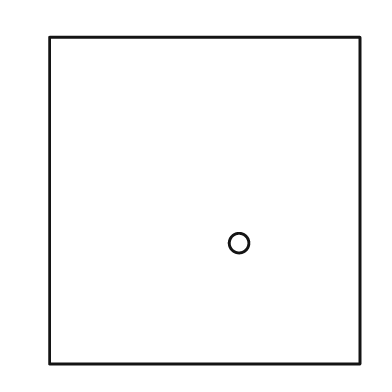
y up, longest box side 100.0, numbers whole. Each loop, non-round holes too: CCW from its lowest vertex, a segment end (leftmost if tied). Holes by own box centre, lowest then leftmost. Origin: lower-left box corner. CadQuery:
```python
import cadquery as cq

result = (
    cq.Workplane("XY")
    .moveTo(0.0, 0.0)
    .lineTo(95.0, 0.0)
    .lineTo(95.0, 100.0)
    .lineTo(0.0, 100.0)
    .close()
    .moveTo(58.0, 37.0)
    .circle(3.0)
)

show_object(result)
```